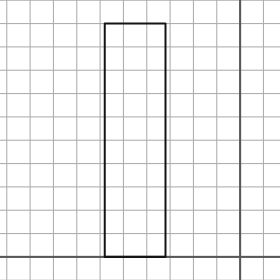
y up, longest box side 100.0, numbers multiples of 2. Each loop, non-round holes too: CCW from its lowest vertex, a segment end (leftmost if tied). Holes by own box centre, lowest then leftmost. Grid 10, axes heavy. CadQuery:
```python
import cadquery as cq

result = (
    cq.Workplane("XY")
    .moveTo(-58.0, 0.0)
    .lineTo(-32.0, 0.0)
    .lineTo(-32.0, 100.0)
    .lineTo(-58.0, 100.0)
    .close()
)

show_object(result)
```